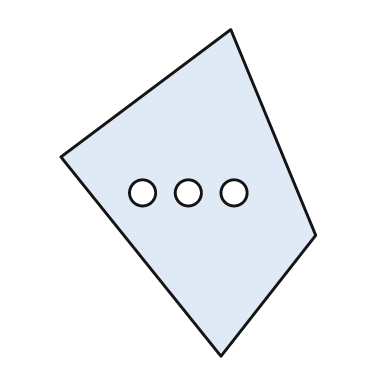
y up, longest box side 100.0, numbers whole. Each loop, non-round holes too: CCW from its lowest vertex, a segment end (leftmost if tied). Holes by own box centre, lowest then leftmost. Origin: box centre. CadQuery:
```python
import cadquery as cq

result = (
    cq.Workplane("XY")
    .moveTo(10.0, -50.0)
    .lineTo(39.0, -13.0)
    .lineTo(13.0, 50.0)
    .lineTo(-39.0, 11.0)
    .close()
    .moveTo(-14.0, 0.0)
    .circle(4.0)
    .moveTo(0.0, 0.0)
    .circle(4.0)
    .moveTo(14.0, 0.0)
    .circle(4.0)
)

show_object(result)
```